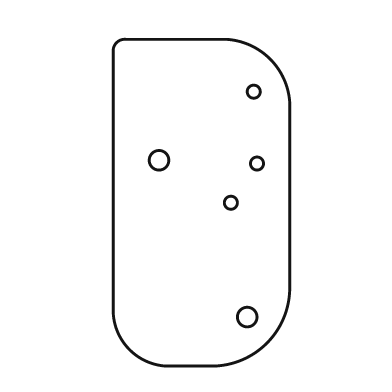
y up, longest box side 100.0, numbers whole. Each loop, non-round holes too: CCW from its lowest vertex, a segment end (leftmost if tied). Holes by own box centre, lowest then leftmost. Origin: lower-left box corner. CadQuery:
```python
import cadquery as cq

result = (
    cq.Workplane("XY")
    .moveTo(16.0, 0.0)
    .lineTo(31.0, 0.0)
    .threePointArc((47.0, 7.0), (54.0, 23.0))
    .lineTo(54.0, 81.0)
    .threePointArc((48.0, 94.0), (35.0, 100.0))
    .lineTo(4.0, 100.0)
    .threePointArc((1.0, 99.0), (0.0, 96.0))
    .lineTo(0.0, 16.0)
    .threePointArc((5.0, 5.0), (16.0, 0.0))
    .close()
    .moveTo(41.0, 15.0)
    .circle(3.0)
    .moveTo(36.0, 50.0)
    .circle(2.0)
    .moveTo(44.0, 62.0)
    .circle(2.0)
    .moveTo(14.0, 63.0)
    .circle(3.0)
    .moveTo(43.0, 84.0)
    .circle(2.0)
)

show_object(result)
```